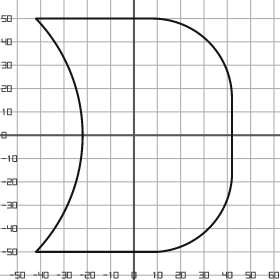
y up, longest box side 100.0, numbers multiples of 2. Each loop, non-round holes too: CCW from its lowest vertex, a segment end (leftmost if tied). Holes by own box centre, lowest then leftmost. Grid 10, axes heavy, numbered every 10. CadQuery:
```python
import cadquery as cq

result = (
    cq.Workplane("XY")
    .moveTo(-42.0, -50.0)
    .lineTo(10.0, -50.0)
    .threePointArc((32.0, -40.0), (42.0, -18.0))
    .lineTo(42.0, 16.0)
    .threePointArc((32.0, 40.0), (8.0, 50.0))
    .lineTo(-42.0, 50.0)
    .threePointArc((-22.0, 0.0), (-42.0, -50.0))
    .close()
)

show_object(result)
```